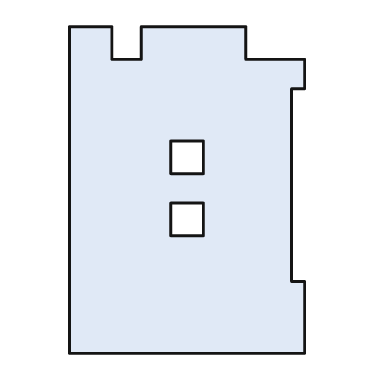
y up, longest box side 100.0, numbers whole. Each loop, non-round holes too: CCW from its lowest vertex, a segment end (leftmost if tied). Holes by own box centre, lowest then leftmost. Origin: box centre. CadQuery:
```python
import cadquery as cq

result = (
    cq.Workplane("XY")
    .moveTo(-36.0, -50.0)
    .lineTo(36.0, -50.0)
    .lineTo(36.0, -28.0)
    .lineTo(32.0, -28.0)
    .lineTo(32.0, 31.0)
    .lineTo(36.0, 31.0)
    .lineTo(36.0, 40.0)
    .lineTo(18.0, 40.0)
    .lineTo(18.0, 50.0)
    .lineTo(-14.0, 50.0)
    .lineTo(-14.0, 40.0)
    .lineTo(-23.0, 40.0)
    .lineTo(-23.0, 50.0)
    .lineTo(-36.0, 50.0)
    .close()
    .moveTo(-5.0, -14.0)
    .lineTo(5.0, -14.0)
    .lineTo(5.0, -4.0)
    .lineTo(-5.0, -4.0)
    .close()
    .moveTo(-5.0, 5.0)
    .lineTo(5.0, 5.0)
    .lineTo(5.0, 15.0)
    .lineTo(-5.0, 15.0)
    .close()
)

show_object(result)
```